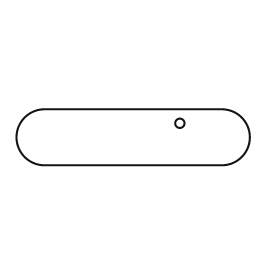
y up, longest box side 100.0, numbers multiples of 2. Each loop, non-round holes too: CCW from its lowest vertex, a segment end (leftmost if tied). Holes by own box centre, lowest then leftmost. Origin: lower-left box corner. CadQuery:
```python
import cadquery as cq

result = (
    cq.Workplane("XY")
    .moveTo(12.0, 0.0)
    .lineTo(88.0, 0.0)
    .threePointArc((100.0, 12.0), (88.0, 24.0))
    .lineTo(12.0, 24.0)
    .threePointArc((0.0, 12.0), (12.0, 0.0))
    .close()
    .moveTo(70.0, 18.0)
    .circle(2.0)
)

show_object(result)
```